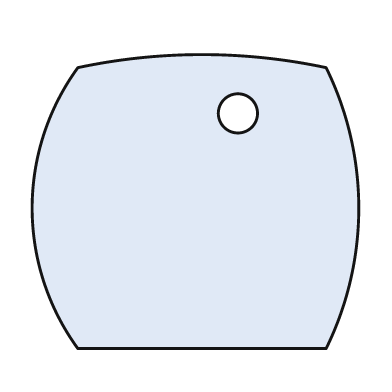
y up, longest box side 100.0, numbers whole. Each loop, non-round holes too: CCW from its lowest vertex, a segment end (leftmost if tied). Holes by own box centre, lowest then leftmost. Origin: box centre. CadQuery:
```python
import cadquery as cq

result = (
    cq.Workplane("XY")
    .moveTo(-36.0, -45.0)
    .lineTo(40.0, -45.0)
    .threePointArc((50.0, -2.0), (40.0, 41.0))
    .threePointArc((2.0, 45.0), (-36.0, 41.0))
    .threePointArc((-50.0, -2.0), (-36.0, -45.0))
    .close()
    .moveTo(13.0, 27.0)
    .circle(6.0)
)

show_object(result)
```